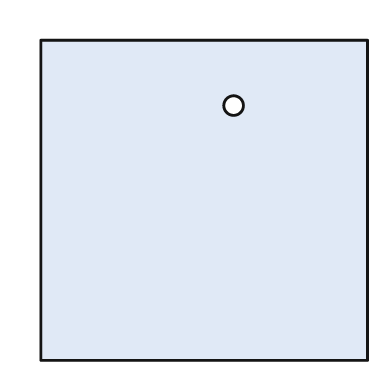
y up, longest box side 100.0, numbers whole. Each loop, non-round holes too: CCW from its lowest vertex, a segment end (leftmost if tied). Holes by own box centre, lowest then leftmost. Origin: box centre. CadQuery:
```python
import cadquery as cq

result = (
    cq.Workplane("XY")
    .moveTo(-50.0, -49.0)
    .lineTo(50.0, -49.0)
    .lineTo(50.0, 49.0)
    .lineTo(-50.0, 49.0)
    .close()
    .moveTo(9.0, 29.0)
    .circle(3.0)
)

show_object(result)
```